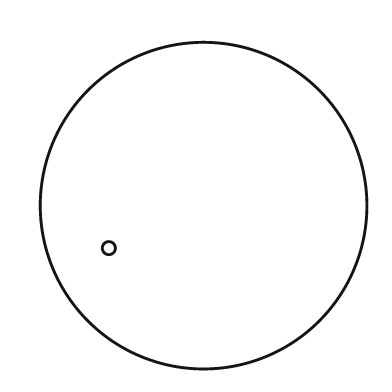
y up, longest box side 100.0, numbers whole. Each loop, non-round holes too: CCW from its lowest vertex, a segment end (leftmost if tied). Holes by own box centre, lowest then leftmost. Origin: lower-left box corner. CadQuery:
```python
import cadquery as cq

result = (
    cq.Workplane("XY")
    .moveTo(50.0, 50.0)
    .circle(50.0)
    .moveTo(21.0, 37.0)
    .circle(2.0)
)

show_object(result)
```